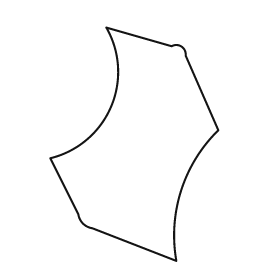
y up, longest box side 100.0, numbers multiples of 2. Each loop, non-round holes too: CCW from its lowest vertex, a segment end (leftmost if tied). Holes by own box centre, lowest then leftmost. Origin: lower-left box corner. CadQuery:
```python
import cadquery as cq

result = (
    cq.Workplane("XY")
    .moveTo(54.0, 0.0)
    .threePointArc((56.0, 30.0), (72.0, 56.0))
    .lineTo(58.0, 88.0)
    .threePointArc((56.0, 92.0), (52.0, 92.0))
    .lineTo(24.0, 100.0)
    .threePointArc((26.0, 66.0), (0.0, 44.0))
    .lineTo(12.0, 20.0)
    .threePointArc((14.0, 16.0), (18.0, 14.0))
    .close()
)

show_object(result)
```